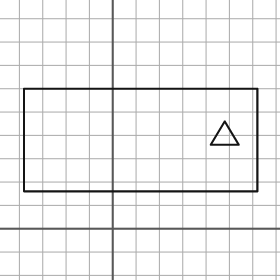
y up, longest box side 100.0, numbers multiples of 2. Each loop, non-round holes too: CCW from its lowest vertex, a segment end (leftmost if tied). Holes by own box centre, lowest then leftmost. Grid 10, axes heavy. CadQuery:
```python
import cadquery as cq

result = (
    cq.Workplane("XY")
    .moveTo(-38.0, 16.0)
    .lineTo(62.0, 16.0)
    .lineTo(62.0, 60.0)
    .lineTo(-38.0, 60.0)
    .close()
    .moveTo(42.0, 36.0)
    .lineTo(54.0, 36.0)
    .lineTo(48.0, 46.0)
    .close()
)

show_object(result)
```